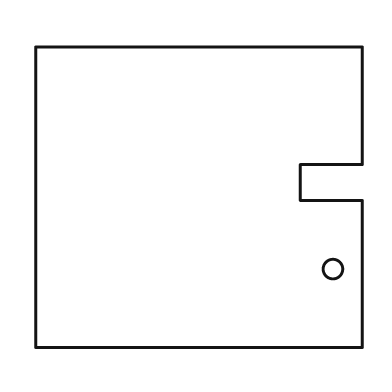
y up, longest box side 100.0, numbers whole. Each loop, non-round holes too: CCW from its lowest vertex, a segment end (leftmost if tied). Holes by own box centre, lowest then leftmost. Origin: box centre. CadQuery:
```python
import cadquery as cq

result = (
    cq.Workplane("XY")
    .moveTo(-50.0, -46.0)
    .lineTo(50.0, -46.0)
    .lineTo(50.0, -1.0)
    .lineTo(31.0, -1.0)
    .lineTo(31.0, 10.0)
    .lineTo(50.0, 10.0)
    .lineTo(50.0, 46.0)
    .lineTo(-50.0, 46.0)
    .close()
    .moveTo(41.0, -22.0)
    .circle(3.0)
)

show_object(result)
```